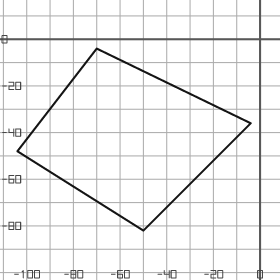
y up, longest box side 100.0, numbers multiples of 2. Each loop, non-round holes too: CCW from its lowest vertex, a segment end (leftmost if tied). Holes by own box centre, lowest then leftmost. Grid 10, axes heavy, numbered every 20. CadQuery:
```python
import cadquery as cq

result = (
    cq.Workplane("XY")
    .moveTo(-50.0, -82.0)
    .lineTo(-4.0, -36.0)
    .lineTo(-70.0, -4.0)
    .lineTo(-104.0, -48.0)
    .close()
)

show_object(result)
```